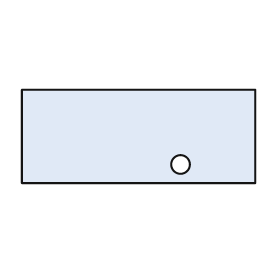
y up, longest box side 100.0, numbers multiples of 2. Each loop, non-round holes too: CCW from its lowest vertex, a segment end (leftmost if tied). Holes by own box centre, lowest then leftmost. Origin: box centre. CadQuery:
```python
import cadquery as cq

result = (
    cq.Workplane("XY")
    .moveTo(-50.0, -20.0)
    .lineTo(50.0, -20.0)
    .lineTo(50.0, 20.0)
    .lineTo(-50.0, 20.0)
    .close()
    .moveTo(18.0, -12.0)
    .circle(4.0)
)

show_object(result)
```